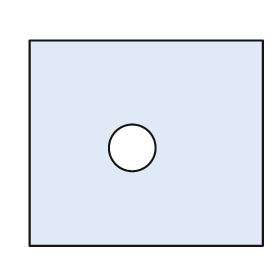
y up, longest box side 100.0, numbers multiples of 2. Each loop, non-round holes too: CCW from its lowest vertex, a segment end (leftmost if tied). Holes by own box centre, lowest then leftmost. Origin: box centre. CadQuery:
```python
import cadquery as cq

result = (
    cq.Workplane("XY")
    .moveTo(-50.0, -44.0)
    .lineTo(50.0, -44.0)
    .lineTo(50.0, 44.0)
    .lineTo(-50.0, 44.0)
    .close()
    .moveTo(-6.0, -2.0)
    .circle(10.0)
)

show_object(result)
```